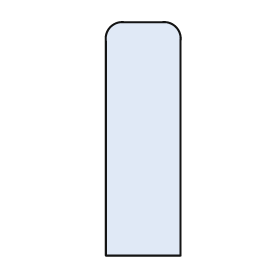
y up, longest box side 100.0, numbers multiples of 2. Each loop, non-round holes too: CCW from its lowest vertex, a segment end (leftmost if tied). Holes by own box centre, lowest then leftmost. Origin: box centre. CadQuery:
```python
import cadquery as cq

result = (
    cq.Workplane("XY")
    .moveTo(-16.0, -50.0)
    .lineTo(16.0, -50.0)
    .lineTo(16.0, 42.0)
    .threePointArc((14.0, 48.0), (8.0, 50.0))
    .lineTo(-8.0, 50.0)
    .threePointArc((-14.0, 48.0), (-16.0, 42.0))
    .close()
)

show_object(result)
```